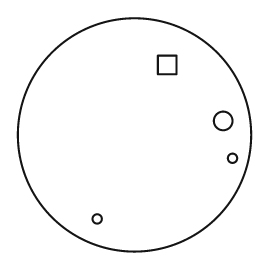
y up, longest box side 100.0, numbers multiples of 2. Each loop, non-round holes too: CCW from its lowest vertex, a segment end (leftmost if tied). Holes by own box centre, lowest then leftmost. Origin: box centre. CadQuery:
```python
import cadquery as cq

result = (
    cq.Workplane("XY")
    .moveTo(0.0, 0.0)
    .circle(50.0)
    .moveTo(-16.0, -36.0)
    .circle(2.0)
    .moveTo(42.0, -10.0)
    .circle(2.0)
    .moveTo(38.0, 6.0)
    .circle(4.0)
    .moveTo(10.0, 26.0)
    .lineTo(18.0, 26.0)
    .lineTo(18.0, 34.0)
    .lineTo(10.0, 34.0)
    .close()
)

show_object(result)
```